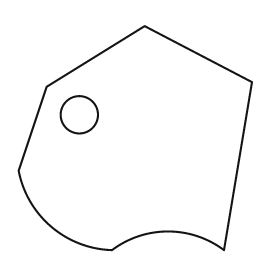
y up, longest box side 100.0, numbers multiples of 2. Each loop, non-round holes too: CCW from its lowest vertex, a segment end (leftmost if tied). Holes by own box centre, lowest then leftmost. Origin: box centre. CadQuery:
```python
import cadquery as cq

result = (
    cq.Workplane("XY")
    .moveTo(-10.0, -48.0)
    .threePointArc((14.0, -40.0), (38.0, -48.0))
    .lineTo(50.0, 24.0)
    .lineTo(4.0, 48.0)
    .lineTo(-38.0, 22.0)
    .lineTo(-50.0, -14.0)
    .threePointArc((-36.0, -38.0), (-10.0, -48.0))
    .close()
    .moveTo(-24.0, 10.0)
    .circle(8.0)
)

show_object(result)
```